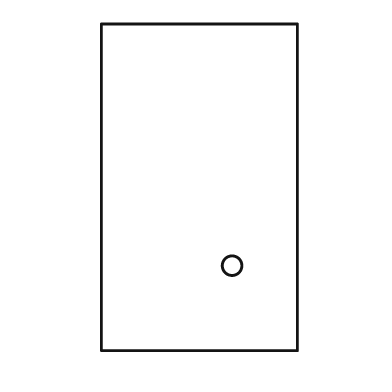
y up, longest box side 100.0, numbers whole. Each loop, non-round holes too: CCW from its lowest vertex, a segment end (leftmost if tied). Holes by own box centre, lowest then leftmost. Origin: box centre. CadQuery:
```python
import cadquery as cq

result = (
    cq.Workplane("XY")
    .moveTo(-30.0, -50.0)
    .lineTo(30.0, -50.0)
    .lineTo(30.0, 50.0)
    .lineTo(-30.0, 50.0)
    .close()
    .moveTo(10.0, -24.0)
    .circle(3.0)
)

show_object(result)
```